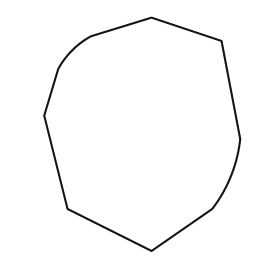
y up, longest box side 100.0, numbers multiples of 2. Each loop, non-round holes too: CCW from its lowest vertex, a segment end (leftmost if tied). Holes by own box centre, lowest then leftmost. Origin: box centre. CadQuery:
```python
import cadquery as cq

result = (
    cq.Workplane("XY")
    .moveTo(4.0, -50.0)
    .lineTo(30.0, -32.0)
    .threePointArc((38.0, -18.0), (42.0, -2.0))
    .lineTo(34.0, 40.0)
    .lineTo(4.0, 50.0)
    .lineTo(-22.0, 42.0)
    .threePointArc((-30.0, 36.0), (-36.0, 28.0))
    .lineTo(-42.0, 8.0)
    .lineTo(-32.0, -32.0)
    .close()
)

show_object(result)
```